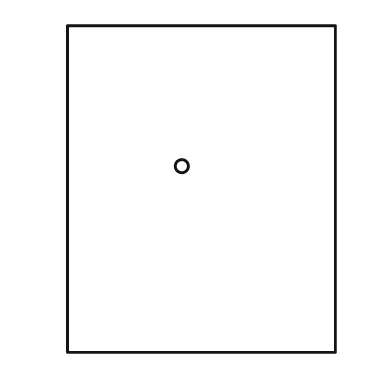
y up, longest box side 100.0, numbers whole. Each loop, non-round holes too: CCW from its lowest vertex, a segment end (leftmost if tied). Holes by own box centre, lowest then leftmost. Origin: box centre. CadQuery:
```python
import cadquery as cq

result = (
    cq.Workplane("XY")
    .moveTo(-41.0, -50.0)
    .lineTo(41.0, -50.0)
    .lineTo(41.0, 50.0)
    .lineTo(-41.0, 50.0)
    .close()
    .moveTo(-6.0, 7.0)
    .circle(2.0)
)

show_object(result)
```